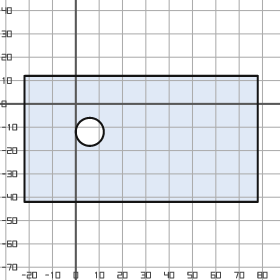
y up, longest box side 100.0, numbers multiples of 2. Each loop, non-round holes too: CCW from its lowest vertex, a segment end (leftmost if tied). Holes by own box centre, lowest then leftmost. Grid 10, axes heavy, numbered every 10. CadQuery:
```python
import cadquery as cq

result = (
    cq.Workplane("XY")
    .moveTo(-22.0, -42.0)
    .lineTo(78.0, -42.0)
    .lineTo(78.0, 12.0)
    .lineTo(-22.0, 12.0)
    .close()
    .moveTo(6.0, -12.0)
    .circle(6.0)
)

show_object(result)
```